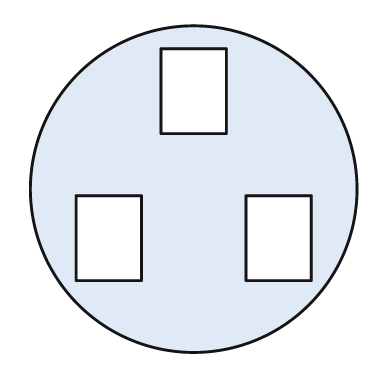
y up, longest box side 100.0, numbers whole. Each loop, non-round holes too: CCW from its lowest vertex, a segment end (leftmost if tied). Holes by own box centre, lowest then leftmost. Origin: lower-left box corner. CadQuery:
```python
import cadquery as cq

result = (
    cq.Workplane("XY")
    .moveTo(50.0, 50.0)
    .circle(50.0)
    .moveTo(14.0, 22.0)
    .lineTo(34.0, 22.0)
    .lineTo(34.0, 48.0)
    .lineTo(14.0, 48.0)
    .close()
    .moveTo(66.0, 22.0)
    .lineTo(86.0, 22.0)
    .lineTo(86.0, 48.0)
    .lineTo(66.0, 48.0)
    .close()
    .moveTo(40.0, 67.0)
    .lineTo(60.0, 67.0)
    .lineTo(60.0, 93.0)
    .lineTo(40.0, 93.0)
    .close()
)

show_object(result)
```